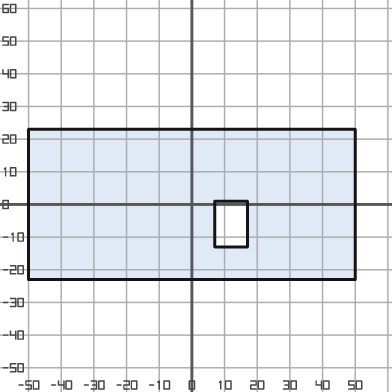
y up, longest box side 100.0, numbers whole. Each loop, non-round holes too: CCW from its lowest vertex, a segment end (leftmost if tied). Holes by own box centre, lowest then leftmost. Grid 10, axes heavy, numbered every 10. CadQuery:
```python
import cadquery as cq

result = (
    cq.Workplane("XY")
    .moveTo(-50.0, -23.0)
    .lineTo(50.0, -23.0)
    .lineTo(50.0, 23.0)
    .lineTo(-50.0, 23.0)
    .close()
    .moveTo(7.0, -13.0)
    .lineTo(17.0, -13.0)
    .lineTo(17.0, 1.0)
    .lineTo(7.0, 1.0)
    .close()
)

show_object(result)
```